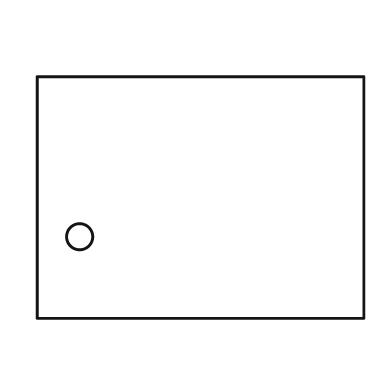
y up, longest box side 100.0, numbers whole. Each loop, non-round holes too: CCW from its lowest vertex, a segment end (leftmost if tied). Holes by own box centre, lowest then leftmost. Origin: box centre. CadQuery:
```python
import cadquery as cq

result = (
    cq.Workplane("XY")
    .moveTo(-50.0, -37.0)
    .lineTo(50.0, -37.0)
    .lineTo(50.0, 37.0)
    .lineTo(-50.0, 37.0)
    .close()
    .moveTo(-37.0, -12.0)
    .circle(4.0)
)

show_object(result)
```